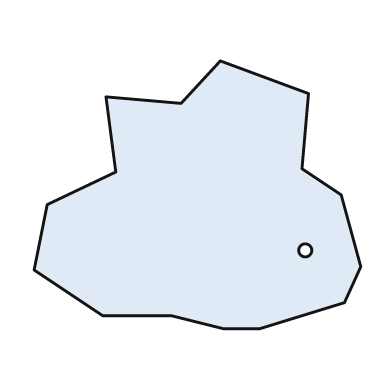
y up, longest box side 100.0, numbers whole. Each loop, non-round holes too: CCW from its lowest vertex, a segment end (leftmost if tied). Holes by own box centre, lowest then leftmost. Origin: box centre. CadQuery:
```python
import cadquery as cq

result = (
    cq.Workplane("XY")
    .moveTo(8.0, -41.0)
    .lineTo(19.0, -41.0)
    .lineTo(45.0, -33.0)
    .lineTo(50.0, -22.0)
    .lineTo(44.0, 0.0)
    .lineTo(32.0, 8.0)
    .lineTo(34.0, 31.0)
    .lineTo(7.0, 41.0)
    .lineTo(-5.0, 28.0)
    .lineTo(-28.0, 30.0)
    .lineTo(-25.0, 7.0)
    .lineTo(-46.0, -3.0)
    .lineTo(-50.0, -23.0)
    .lineTo(-29.0, -37.0)
    .lineTo(-8.0, -37.0)
    .close()
    .moveTo(33.0, -17.0)
    .circle(2.0)
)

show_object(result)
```